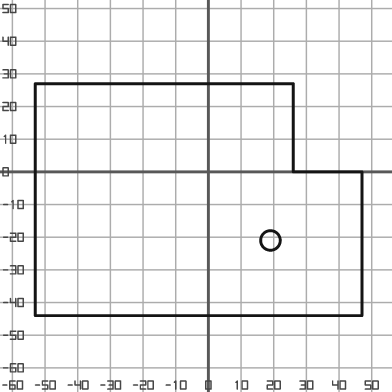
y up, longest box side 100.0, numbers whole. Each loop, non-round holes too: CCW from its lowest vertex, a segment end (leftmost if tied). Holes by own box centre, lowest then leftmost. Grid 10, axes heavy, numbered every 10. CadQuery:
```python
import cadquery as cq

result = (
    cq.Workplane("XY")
    .moveTo(-53.0, -44.0)
    .lineTo(47.0, -44.0)
    .lineTo(47.0, 0.0)
    .lineTo(26.0, 0.0)
    .lineTo(26.0, 27.0)
    .lineTo(-53.0, 27.0)
    .close()
    .moveTo(19.0, -21.0)
    .circle(3.0)
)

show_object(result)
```